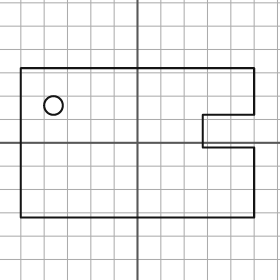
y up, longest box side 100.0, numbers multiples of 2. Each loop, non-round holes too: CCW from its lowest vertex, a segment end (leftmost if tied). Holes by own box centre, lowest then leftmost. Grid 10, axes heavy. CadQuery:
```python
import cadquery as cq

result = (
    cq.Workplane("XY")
    .moveTo(-50.0, -32.0)
    .lineTo(50.0, -32.0)
    .lineTo(50.0, -2.0)
    .lineTo(28.0, -2.0)
    .lineTo(28.0, 12.0)
    .lineTo(50.0, 12.0)
    .lineTo(50.0, 32.0)
    .lineTo(-50.0, 32.0)
    .close()
    .moveTo(-36.0, 16.0)
    .circle(4.0)
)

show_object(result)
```